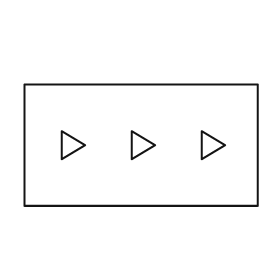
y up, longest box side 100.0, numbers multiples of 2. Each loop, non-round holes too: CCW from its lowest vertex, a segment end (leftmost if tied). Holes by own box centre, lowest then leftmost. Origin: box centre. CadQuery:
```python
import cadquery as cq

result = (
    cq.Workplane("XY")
    .moveTo(-50.0, -26.0)
    .lineTo(50.0, -26.0)
    .lineTo(50.0, 26.0)
    .lineTo(-50.0, 26.0)
    .close()
    .moveTo(-34.0, -6.0)
    .lineTo(-24.0, 0.0)
    .lineTo(-34.0, 6.0)
    .close()
    .moveTo(-4.0, -6.0)
    .lineTo(6.0, 0.0)
    .lineTo(-4.0, 6.0)
    .close()
    .moveTo(26.0, -6.0)
    .lineTo(36.0, 0.0)
    .lineTo(26.0, 6.0)
    .close()
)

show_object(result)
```